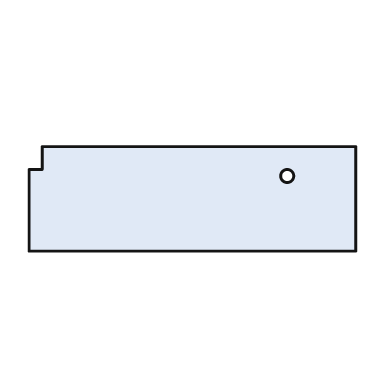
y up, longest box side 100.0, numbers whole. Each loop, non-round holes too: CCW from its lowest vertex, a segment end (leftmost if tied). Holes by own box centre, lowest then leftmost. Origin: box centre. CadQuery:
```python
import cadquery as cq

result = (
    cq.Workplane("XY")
    .moveTo(-50.0, -16.0)
    .lineTo(50.0, -16.0)
    .lineTo(50.0, 16.0)
    .lineTo(-46.0, 16.0)
    .lineTo(-46.0, 9.0)
    .lineTo(-50.0, 9.0)
    .close()
    .moveTo(29.0, 7.0)
    .circle(2.0)
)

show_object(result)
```